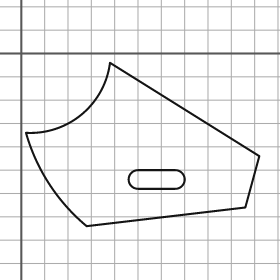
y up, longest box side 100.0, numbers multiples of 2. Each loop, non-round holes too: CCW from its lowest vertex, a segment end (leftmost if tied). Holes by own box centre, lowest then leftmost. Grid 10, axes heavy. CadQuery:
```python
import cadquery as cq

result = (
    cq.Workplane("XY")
    .moveTo(28.0, -74.0)
    .lineTo(96.0, -66.0)
    .lineTo(102.0, -44.0)
    .lineTo(38.0, -4.0)
    .threePointArc((26.0, -26.0), (2.0, -34.0))
    .threePointArc((12.0, -56.0), (28.0, -74.0))
    .close()
    .moveTo(50.0, -58.0)
    .lineTo(66.0, -58.0)
    .threePointArc((70.0, -54.0), (66.0, -50.0))
    .lineTo(50.0, -50.0)
    .threePointArc((46.0, -54.0), (50.0, -58.0))
    .close()
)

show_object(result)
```